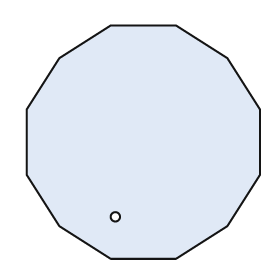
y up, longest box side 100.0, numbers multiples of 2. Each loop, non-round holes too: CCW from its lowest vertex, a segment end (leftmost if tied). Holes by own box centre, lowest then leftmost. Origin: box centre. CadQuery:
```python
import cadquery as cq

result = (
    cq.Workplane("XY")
    .moveTo(-14.0, -50.0)
    .lineTo(14.0, -50.0)
    .lineTo(36.0, -36.0)
    .lineTo(50.0, -14.0)
    .lineTo(50.0, 14.0)
    .lineTo(36.0, 36.0)
    .lineTo(14.0, 50.0)
    .lineTo(-14.0, 50.0)
    .lineTo(-36.0, 36.0)
    .lineTo(-50.0, 14.0)
    .lineTo(-50.0, -14.0)
    .lineTo(-36.0, -36.0)
    .close()
    .moveTo(-12.0, -32.0)
    .circle(2.0)
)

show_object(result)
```